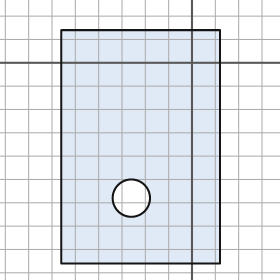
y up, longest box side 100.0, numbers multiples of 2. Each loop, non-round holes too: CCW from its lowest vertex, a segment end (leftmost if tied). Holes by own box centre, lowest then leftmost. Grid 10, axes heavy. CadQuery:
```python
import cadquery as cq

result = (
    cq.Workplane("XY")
    .moveTo(-56.0, -86.0)
    .lineTo(12.0, -86.0)
    .lineTo(12.0, 14.0)
    .lineTo(-56.0, 14.0)
    .close()
    .moveTo(-26.0, -58.0)
    .circle(8.0)
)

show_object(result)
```